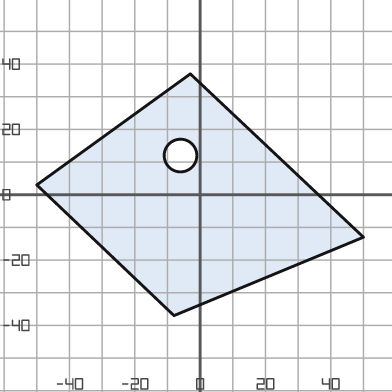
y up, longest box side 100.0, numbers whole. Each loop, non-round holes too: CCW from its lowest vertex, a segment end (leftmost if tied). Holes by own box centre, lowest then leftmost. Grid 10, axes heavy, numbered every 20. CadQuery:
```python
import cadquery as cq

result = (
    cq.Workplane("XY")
    .moveTo(-8.0, -37.0)
    .lineTo(50.0, -13.0)
    .lineTo(-3.0, 37.0)
    .lineTo(-50.0, 3.0)
    .close()
    .moveTo(-6.0, 12.0)
    .circle(5.0)
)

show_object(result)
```